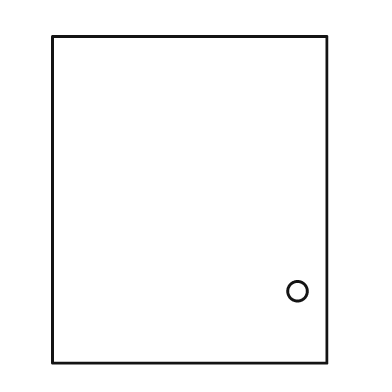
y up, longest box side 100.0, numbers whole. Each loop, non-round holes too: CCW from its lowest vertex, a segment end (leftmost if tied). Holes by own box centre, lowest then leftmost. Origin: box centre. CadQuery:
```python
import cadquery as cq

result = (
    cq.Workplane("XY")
    .moveTo(-42.0, -50.0)
    .lineTo(42.0, -50.0)
    .lineTo(42.0, 50.0)
    .lineTo(-42.0, 50.0)
    .close()
    .moveTo(33.0, -28.0)
    .circle(3.0)
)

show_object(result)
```